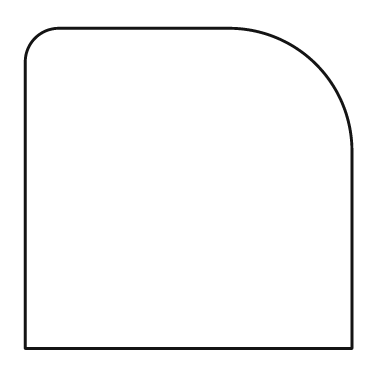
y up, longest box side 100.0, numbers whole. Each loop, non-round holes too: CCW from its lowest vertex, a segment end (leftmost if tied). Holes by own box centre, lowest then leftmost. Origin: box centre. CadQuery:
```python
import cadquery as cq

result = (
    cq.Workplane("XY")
    .moveTo(-50.0, -49.0)
    .lineTo(50.0, -49.0)
    .lineTo(50.0, 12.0)
    .threePointArc((39.0, 38.0), (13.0, 49.0))
    .lineTo(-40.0, 49.0)
    .threePointArc((-47.0, 46.0), (-50.0, 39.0))
    .close()
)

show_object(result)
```